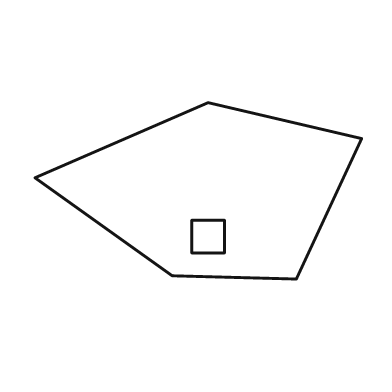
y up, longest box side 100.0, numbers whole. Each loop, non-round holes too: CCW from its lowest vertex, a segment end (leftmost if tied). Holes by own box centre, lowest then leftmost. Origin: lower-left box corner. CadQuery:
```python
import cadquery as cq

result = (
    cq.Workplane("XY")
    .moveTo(80.0, 0.0)
    .lineTo(100.0, 43.0)
    .lineTo(53.0, 54.0)
    .lineTo(0.0, 31.0)
    .lineTo(42.0, 1.0)
    .close()
    .moveTo(48.0, 8.0)
    .lineTo(58.0, 8.0)
    .lineTo(58.0, 18.0)
    .lineTo(48.0, 18.0)
    .close()
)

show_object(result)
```